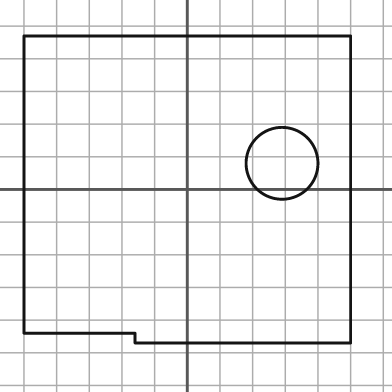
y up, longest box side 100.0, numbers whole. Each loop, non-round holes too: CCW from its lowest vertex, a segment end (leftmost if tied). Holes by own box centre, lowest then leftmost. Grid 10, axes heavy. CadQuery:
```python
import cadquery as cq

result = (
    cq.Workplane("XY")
    .moveTo(-16.0, -47.0)
    .lineTo(50.0, -47.0)
    .lineTo(50.0, 47.0)
    .lineTo(-50.0, 47.0)
    .lineTo(-50.0, -44.0)
    .lineTo(-16.0, -44.0)
    .close()
    .moveTo(29.0, 8.0)
    .circle(11.0)
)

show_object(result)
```